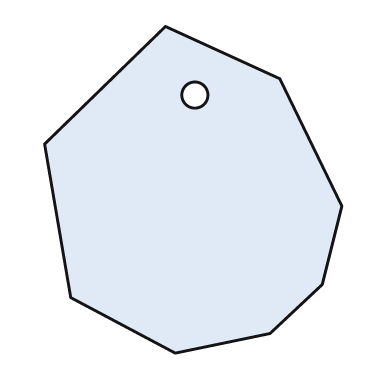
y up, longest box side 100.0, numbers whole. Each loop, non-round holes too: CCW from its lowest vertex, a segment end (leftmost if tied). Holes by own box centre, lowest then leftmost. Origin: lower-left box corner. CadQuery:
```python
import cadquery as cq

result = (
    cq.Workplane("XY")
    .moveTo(40.0, 0.0)
    .lineTo(69.0, 6.0)
    .lineTo(85.0, 21.0)
    .lineTo(91.0, 45.0)
    .lineTo(72.0, 84.0)
    .lineTo(37.0, 100.0)
    .lineTo(0.0, 64.0)
    .lineTo(8.0, 17.0)
    .close()
    .moveTo(46.0, 79.0)
    .circle(4.0)
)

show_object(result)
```